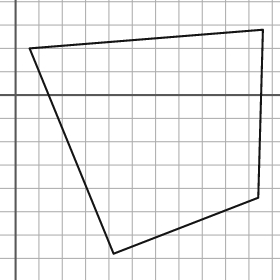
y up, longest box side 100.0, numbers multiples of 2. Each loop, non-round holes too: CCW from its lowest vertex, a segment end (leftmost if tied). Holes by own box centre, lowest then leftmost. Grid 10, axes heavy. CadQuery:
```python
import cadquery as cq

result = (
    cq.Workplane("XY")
    .moveTo(42.0, -68.0)
    .lineTo(104.0, -44.0)
    .lineTo(106.0, 28.0)
    .lineTo(6.0, 20.0)
    .close()
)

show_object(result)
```